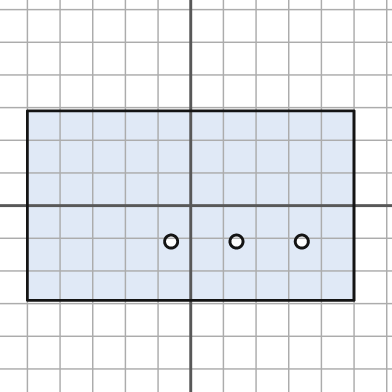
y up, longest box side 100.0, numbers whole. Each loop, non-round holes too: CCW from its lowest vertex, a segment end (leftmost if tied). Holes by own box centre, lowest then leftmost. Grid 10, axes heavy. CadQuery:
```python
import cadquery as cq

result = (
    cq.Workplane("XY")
    .moveTo(-50.0, -29.0)
    .lineTo(50.0, -29.0)
    .lineTo(50.0, 29.0)
    .lineTo(-50.0, 29.0)
    .close()
    .moveTo(-6.0, -11.0)
    .circle(2.0)
    .moveTo(14.0, -11.0)
    .circle(2.0)
    .moveTo(34.0, -11.0)
    .circle(2.0)
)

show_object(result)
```